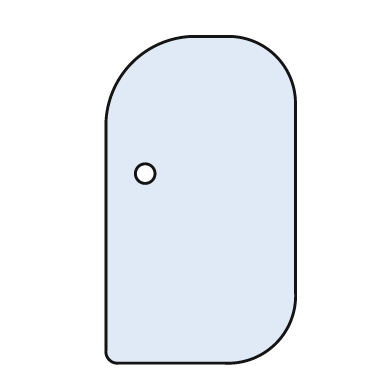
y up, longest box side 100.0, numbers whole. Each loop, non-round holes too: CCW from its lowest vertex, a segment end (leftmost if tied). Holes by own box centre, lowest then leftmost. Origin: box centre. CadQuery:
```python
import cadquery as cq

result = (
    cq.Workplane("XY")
    .moveTo(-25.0, -50.0)
    .lineTo(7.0, -50.0)
    .threePointArc((23.0, -44.0), (29.0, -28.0))
    .lineTo(29.0, 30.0)
    .threePointArc((23.0, 44.0), (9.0, 50.0))
    .lineTo(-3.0, 50.0)
    .threePointArc((-21.0, 42.0), (-29.0, 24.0))
    .lineTo(-29.0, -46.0)
    .threePointArc((-28.0, -49.0), (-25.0, -50.0))
    .close()
    .moveTo(-17.0, 8.0)
    .circle(3.0)
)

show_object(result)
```